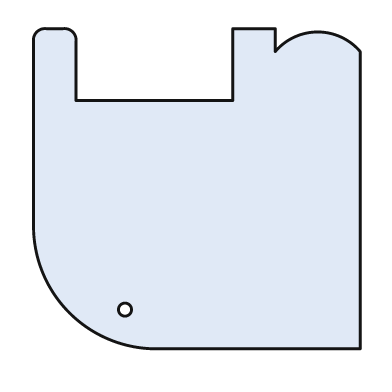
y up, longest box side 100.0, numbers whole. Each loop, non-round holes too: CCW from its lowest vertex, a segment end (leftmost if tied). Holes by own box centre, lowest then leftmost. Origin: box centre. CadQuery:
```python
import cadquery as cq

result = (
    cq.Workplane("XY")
    .moveTo(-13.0, -49.0)
    .lineTo(50.0, -49.0)
    .lineTo(50.0, 42.0)
    .threePointArc((37.0, 48.0), (24.0, 42.0))
    .lineTo(24.0, 49.0)
    .lineTo(11.0, 49.0)
    .lineTo(11.0, 27.0)
    .lineTo(-37.0, 27.0)
    .lineTo(-37.0, 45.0)
    .threePointArc((-38.0, 48.0), (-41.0, 49.0))
    .lineTo(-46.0, 49.0)
    .threePointArc((-49.0, 48.0), (-50.0, 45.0))
    .lineTo(-50.0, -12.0)
    .threePointArc((-39.0, -38.0), (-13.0, -49.0))
    .close()
    .moveTo(-22.0, -37.0)
    .circle(2.0)
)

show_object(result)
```